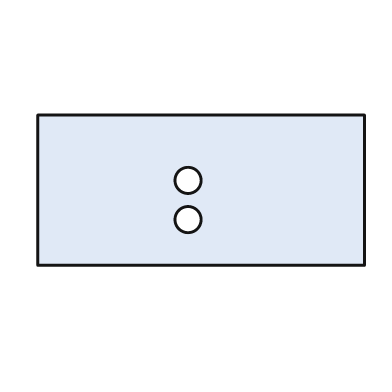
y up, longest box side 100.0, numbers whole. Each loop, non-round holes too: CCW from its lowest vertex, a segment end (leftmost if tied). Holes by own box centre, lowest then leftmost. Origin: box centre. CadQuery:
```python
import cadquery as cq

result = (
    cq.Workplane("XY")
    .moveTo(-50.0, -23.0)
    .lineTo(50.0, -23.0)
    .lineTo(50.0, 23.0)
    .lineTo(-50.0, 23.0)
    .close()
    .moveTo(-4.0, -9.0)
    .circle(4.0)
    .moveTo(-4.0, 3.0)
    .circle(4.0)
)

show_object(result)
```